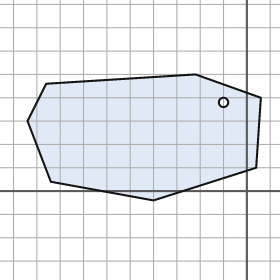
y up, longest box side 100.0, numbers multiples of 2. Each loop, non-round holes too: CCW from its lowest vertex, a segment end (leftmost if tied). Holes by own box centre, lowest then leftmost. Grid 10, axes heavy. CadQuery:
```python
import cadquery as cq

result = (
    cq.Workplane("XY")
    .moveTo(-40.0, -4.0)
    .lineTo(4.0, 10.0)
    .lineTo(6.0, 40.0)
    .lineTo(-22.0, 50.0)
    .lineTo(-86.0, 46.0)
    .lineTo(-94.0, 30.0)
    .lineTo(-84.0, 4.0)
    .close()
    .moveTo(-10.0, 38.0)
    .circle(2.0)
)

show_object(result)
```